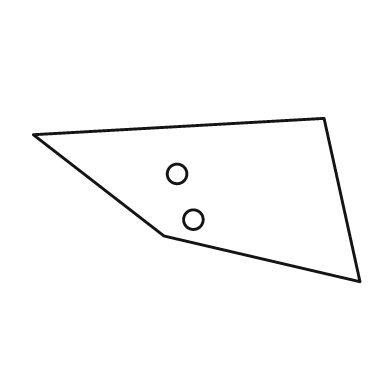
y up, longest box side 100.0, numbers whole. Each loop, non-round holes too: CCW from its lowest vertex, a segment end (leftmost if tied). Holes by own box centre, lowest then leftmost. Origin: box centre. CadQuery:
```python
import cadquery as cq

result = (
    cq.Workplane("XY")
    .moveTo(50.0, -25.0)
    .lineTo(39.0, 25.0)
    .lineTo(-50.0, 20.0)
    .lineTo(-10.0, -11.0)
    .close()
    .moveTo(-1.0, -6.0)
    .circle(3.0)
    .moveTo(-6.0, 8.0)
    .circle(3.0)
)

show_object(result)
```